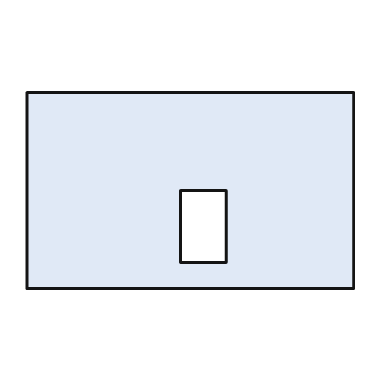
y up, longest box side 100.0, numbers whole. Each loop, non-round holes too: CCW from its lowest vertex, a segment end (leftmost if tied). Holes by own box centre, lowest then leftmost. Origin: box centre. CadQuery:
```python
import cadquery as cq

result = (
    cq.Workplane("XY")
    .moveTo(-50.0, -30.0)
    .lineTo(50.0, -30.0)
    .lineTo(50.0, 30.0)
    .lineTo(-50.0, 30.0)
    .close()
    .moveTo(-3.0, -22.0)
    .lineTo(11.0, -22.0)
    .lineTo(11.0, 0.0)
    .lineTo(-3.0, 0.0)
    .close()
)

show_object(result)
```